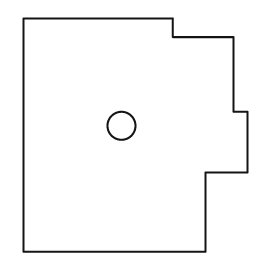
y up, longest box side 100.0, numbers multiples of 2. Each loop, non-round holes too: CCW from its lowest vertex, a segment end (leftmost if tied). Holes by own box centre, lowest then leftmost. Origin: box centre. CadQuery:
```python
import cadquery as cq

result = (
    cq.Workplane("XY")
    .moveTo(-48.0, -50.0)
    .lineTo(30.0, -50.0)
    .lineTo(30.0, -16.0)
    .lineTo(48.0, -16.0)
    .lineTo(48.0, 10.0)
    .lineTo(42.0, 10.0)
    .lineTo(42.0, 42.0)
    .lineTo(16.0, 42.0)
    .lineTo(16.0, 50.0)
    .lineTo(-48.0, 50.0)
    .close()
    .moveTo(-6.0, 4.0)
    .circle(6.0)
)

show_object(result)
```